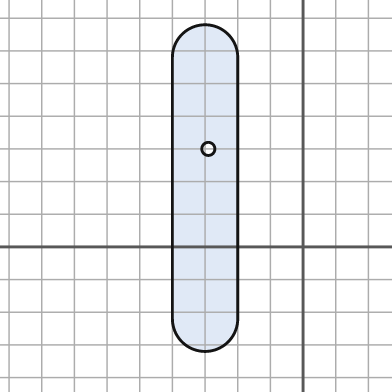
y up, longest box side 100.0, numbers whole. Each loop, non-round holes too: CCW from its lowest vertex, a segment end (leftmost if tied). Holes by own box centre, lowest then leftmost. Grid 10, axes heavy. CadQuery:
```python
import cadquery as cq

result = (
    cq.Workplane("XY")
    .moveTo(-40.0, -22.0)
    .threePointArc((-30.0, -32.0), (-20.0, -22.0))
    .lineTo(-20.0, 58.0)
    .threePointArc((-30.0, 68.0), (-40.0, 58.0))
    .close()
    .moveTo(-29.0, 30.0)
    .circle(2.0)
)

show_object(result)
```